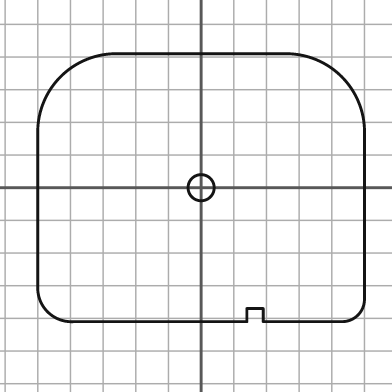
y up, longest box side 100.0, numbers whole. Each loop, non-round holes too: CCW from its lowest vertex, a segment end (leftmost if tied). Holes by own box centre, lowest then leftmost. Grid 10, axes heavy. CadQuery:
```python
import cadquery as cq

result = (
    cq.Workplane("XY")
    .moveTo(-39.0, -41.0)
    .lineTo(14.0, -41.0)
    .lineTo(14.0, -37.0)
    .lineTo(19.0, -37.0)
    .lineTo(19.0, -41.0)
    .lineTo(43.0, -41.0)
    .threePointArc((48.0, -39.0), (50.0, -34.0))
    .lineTo(50.0, 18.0)
    .threePointArc((43.0, 34.0), (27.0, 41.0))
    .lineTo(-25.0, 41.0)
    .threePointArc((-43.0, 34.0), (-50.0, 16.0))
    .lineTo(-50.0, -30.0)
    .threePointArc((-47.0, -38.0), (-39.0, -41.0))
    .close()
    .moveTo(0.0, 0.0)
    .circle(4.0)
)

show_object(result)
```